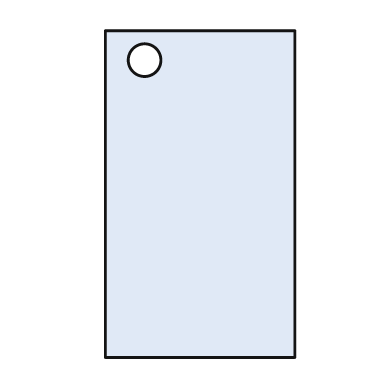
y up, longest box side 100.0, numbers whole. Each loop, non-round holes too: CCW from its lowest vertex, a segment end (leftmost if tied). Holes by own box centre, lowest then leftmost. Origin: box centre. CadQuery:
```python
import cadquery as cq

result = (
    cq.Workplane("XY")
    .moveTo(-29.0, -50.0)
    .lineTo(29.0, -50.0)
    .lineTo(29.0, 50.0)
    .lineTo(-29.0, 50.0)
    .close()
    .moveTo(-17.0, 41.0)
    .circle(5.0)
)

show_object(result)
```